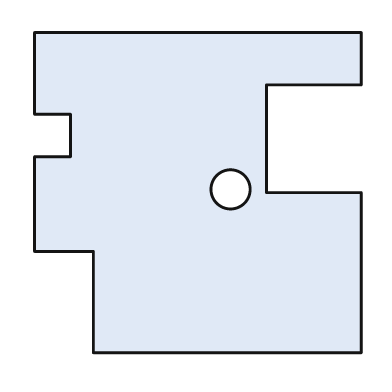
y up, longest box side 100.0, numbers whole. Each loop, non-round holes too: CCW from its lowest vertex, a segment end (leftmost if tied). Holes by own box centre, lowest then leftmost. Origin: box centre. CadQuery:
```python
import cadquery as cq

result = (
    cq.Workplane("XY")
    .moveTo(-32.0, -49.0)
    .lineTo(50.0, -49.0)
    .lineTo(50.0, 0.0)
    .lineTo(21.0, 0.0)
    .lineTo(21.0, 33.0)
    .lineTo(50.0, 33.0)
    .lineTo(50.0, 49.0)
    .lineTo(-50.0, 49.0)
    .lineTo(-50.0, 24.0)
    .lineTo(-39.0, 24.0)
    .lineTo(-39.0, 11.0)
    .lineTo(-50.0, 11.0)
    .lineTo(-50.0, -18.0)
    .lineTo(-32.0, -18.0)
    .close()
    .moveTo(10.0, 1.0)
    .circle(6.0)
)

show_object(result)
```